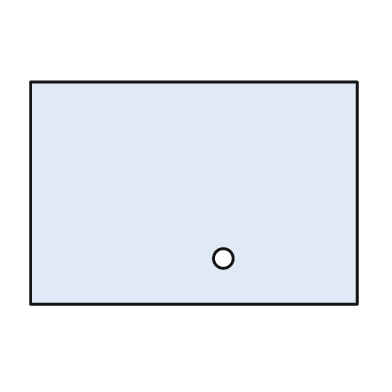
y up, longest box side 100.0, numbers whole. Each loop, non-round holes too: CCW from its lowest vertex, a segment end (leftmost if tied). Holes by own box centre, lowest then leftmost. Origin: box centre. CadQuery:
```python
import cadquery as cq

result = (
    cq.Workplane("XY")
    .moveTo(-50.0, -34.0)
    .lineTo(50.0, -34.0)
    .lineTo(50.0, 34.0)
    .lineTo(-50.0, 34.0)
    .close()
    .moveTo(9.0, -20.0)
    .circle(3.0)
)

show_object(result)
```